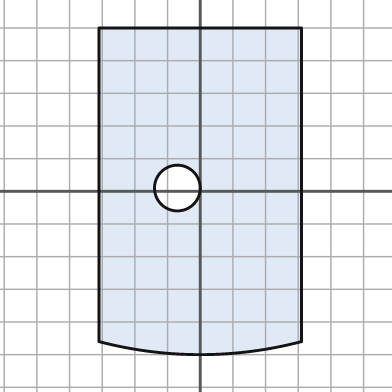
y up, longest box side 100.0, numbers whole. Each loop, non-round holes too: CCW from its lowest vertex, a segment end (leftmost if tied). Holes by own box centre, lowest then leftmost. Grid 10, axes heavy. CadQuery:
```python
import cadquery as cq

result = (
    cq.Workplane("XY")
    .moveTo(-31.0, -46.0)
    .threePointArc((0.0, -50.0), (31.0, -46.0))
    .lineTo(31.0, 50.0)
    .lineTo(-31.0, 50.0)
    .close()
    .moveTo(-7.0, 1.0)
    .circle(7.0)
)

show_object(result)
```